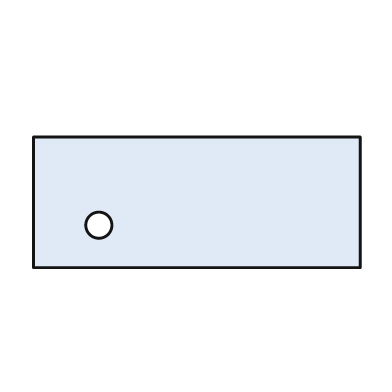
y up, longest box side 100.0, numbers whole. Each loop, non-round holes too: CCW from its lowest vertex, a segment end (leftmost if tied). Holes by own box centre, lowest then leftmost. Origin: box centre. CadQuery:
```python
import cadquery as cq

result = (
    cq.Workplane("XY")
    .moveTo(-50.0, -20.0)
    .lineTo(50.0, -20.0)
    .lineTo(50.0, 20.0)
    .lineTo(-50.0, 20.0)
    .close()
    .moveTo(-30.0, -7.0)
    .circle(4.0)
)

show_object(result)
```